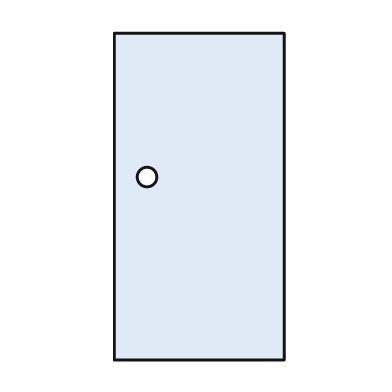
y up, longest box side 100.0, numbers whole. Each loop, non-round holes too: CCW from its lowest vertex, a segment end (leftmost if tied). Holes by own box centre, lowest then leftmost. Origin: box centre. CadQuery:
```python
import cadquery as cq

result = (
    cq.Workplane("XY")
    .moveTo(-26.0, -50.0)
    .lineTo(26.0, -50.0)
    .lineTo(26.0, 50.0)
    .lineTo(-26.0, 50.0)
    .close()
    .moveTo(-16.0, 6.0)
    .circle(3.0)
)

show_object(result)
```